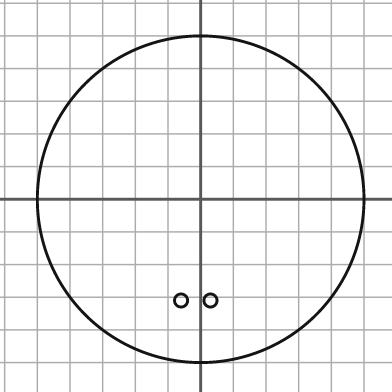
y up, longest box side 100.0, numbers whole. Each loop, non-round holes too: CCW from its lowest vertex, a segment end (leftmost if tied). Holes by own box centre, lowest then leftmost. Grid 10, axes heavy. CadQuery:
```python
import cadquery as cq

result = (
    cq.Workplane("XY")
    .moveTo(0.0, 0.0)
    .circle(50.0)
    .moveTo(-6.0, -31.0)
    .circle(2.0)
    .moveTo(3.0, -31.0)
    .circle(2.0)
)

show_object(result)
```